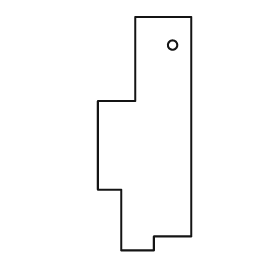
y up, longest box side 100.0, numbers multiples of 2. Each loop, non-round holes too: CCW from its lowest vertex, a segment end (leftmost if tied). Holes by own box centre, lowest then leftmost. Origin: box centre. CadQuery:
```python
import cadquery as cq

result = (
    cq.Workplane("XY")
    .moveTo(-10.0, -50.0)
    .lineTo(4.0, -50.0)
    .lineTo(4.0, -44.0)
    .lineTo(20.0, -44.0)
    .lineTo(20.0, 50.0)
    .lineTo(-4.0, 50.0)
    .lineTo(-4.0, 14.0)
    .lineTo(-20.0, 14.0)
    .lineTo(-20.0, -24.0)
    .lineTo(-10.0, -24.0)
    .close()
    .moveTo(12.0, 38.0)
    .circle(2.0)
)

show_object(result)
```